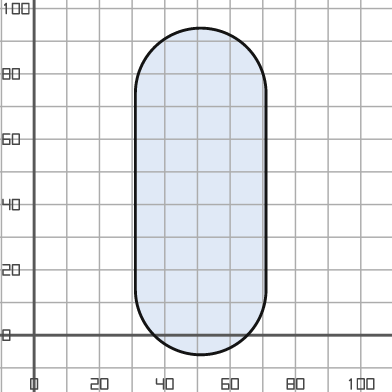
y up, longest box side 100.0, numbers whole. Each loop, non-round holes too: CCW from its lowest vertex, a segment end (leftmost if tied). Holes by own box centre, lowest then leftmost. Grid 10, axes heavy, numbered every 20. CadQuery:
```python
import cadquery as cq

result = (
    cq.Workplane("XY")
    .moveTo(31.0, 14.0)
    .threePointArc((51.0, -6.0), (71.0, 14.0))
    .lineTo(71.0, 74.0)
    .threePointArc((51.0, 94.0), (31.0, 74.0))
    .close()
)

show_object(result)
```